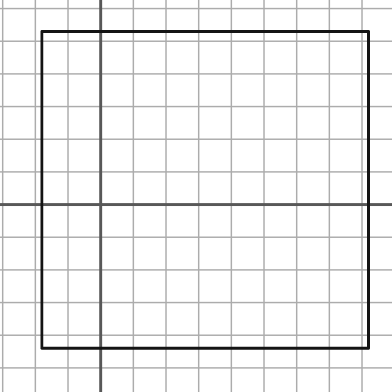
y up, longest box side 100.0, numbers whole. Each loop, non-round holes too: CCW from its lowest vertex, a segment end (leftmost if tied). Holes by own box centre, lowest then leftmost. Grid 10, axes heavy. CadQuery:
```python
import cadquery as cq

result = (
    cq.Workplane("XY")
    .moveTo(-18.0, -44.0)
    .lineTo(82.0, -44.0)
    .lineTo(82.0, 53.0)
    .lineTo(-18.0, 53.0)
    .close()
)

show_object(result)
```